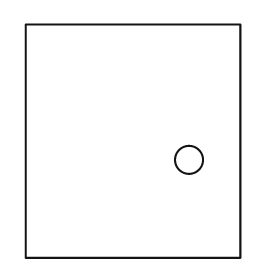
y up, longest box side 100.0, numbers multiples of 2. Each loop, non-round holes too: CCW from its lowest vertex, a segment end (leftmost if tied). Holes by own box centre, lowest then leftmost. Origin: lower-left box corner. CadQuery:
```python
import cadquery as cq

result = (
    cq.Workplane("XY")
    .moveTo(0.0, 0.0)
    .lineTo(92.0, 0.0)
    .lineTo(92.0, 100.0)
    .lineTo(0.0, 100.0)
    .close()
    .moveTo(70.0, 42.0)
    .circle(6.0)
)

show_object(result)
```